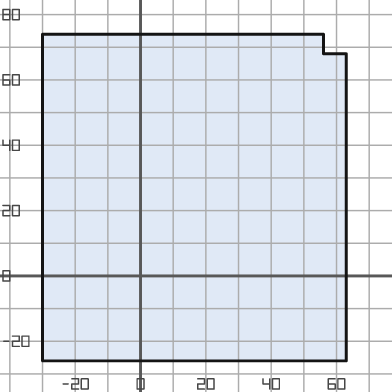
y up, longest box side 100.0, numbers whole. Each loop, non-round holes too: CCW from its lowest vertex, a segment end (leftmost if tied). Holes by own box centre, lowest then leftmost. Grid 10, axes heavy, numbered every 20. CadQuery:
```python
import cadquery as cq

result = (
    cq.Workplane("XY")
    .moveTo(-30.0, -26.0)
    .lineTo(63.0, -26.0)
    .lineTo(63.0, 68.0)
    .lineTo(56.0, 68.0)
    .lineTo(56.0, 74.0)
    .lineTo(-30.0, 74.0)
    .close()
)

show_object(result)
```